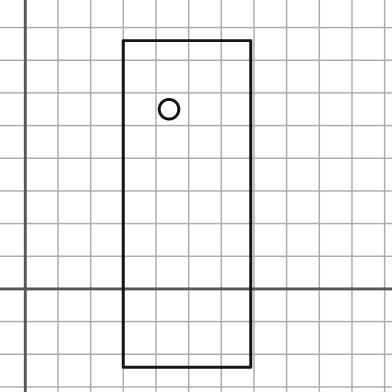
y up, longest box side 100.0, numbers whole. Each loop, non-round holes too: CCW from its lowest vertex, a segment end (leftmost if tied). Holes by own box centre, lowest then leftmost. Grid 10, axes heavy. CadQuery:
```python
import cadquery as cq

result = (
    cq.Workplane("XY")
    .moveTo(30.0, -24.0)
    .lineTo(69.0, -24.0)
    .lineTo(69.0, 76.0)
    .lineTo(30.0, 76.0)
    .close()
    .moveTo(44.0, 55.0)
    .circle(3.0)
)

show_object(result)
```